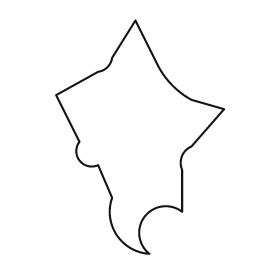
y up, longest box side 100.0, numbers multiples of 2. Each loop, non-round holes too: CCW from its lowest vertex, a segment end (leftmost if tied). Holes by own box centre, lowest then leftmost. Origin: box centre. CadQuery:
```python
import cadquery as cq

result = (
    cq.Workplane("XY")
    .moveTo(4.0, -50.0)
    .threePointArc((2.0, -34.0), (18.0, -32.0))
    .lineTo(18.0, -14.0)
    .threePointArc((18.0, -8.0), (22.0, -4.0))
    .lineTo(36.0, 12.0)
    .lineTo(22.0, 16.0)
    .threePointArc((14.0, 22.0), (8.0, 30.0))
    .lineTo(-2.0, 50.0)
    .lineTo(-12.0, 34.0)
    .threePointArc((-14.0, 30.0), (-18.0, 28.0))
    .lineTo(-36.0, 18.0)
    .lineTo(-26.0, -2.0)
    .threePointArc((-26.0, -10.0), (-18.0, -12.0))
    .lineTo(-12.0, -26.0)
    .threePointArc((-10.0, -42.0), (4.0, -50.0))
    .close()
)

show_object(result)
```